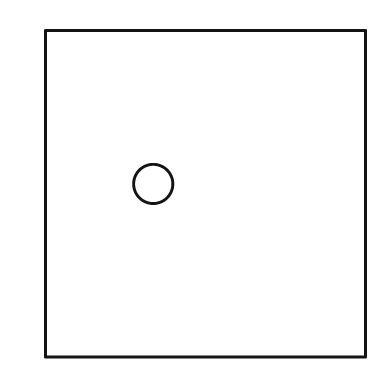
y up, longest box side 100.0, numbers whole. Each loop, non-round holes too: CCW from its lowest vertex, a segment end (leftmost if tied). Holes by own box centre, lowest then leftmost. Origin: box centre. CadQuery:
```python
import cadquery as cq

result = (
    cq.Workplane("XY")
    .moveTo(-49.0, -50.0)
    .lineTo(49.0, -50.0)
    .lineTo(49.0, 50.0)
    .lineTo(-49.0, 50.0)
    .close()
    .moveTo(-16.0, 3.0)
    .circle(6.0)
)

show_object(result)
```